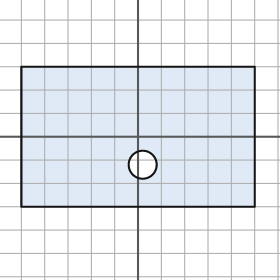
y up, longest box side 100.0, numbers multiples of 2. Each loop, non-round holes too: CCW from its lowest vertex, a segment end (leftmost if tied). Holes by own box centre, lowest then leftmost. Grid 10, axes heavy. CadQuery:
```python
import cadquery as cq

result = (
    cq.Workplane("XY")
    .moveTo(-50.0, -30.0)
    .lineTo(50.0, -30.0)
    .lineTo(50.0, 30.0)
    .lineTo(-50.0, 30.0)
    .close()
    .moveTo(2.0, -12.0)
    .circle(6.0)
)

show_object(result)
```